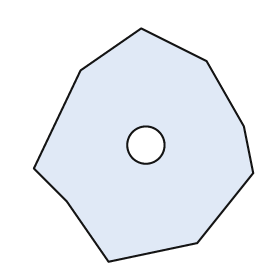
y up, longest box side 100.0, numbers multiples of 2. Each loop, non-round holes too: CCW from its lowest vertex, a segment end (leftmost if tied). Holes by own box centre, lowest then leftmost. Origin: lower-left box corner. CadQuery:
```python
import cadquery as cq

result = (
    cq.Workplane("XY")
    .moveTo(32.0, 0.0)
    .lineTo(70.0, 8.0)
    .lineTo(94.0, 38.0)
    .lineTo(90.0, 58.0)
    .lineTo(74.0, 86.0)
    .lineTo(46.0, 100.0)
    .lineTo(20.0, 82.0)
    .lineTo(0.0, 40.0)
    .lineTo(14.0, 26.0)
    .close()
    .moveTo(48.0, 50.0)
    .circle(8.0)
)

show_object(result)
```